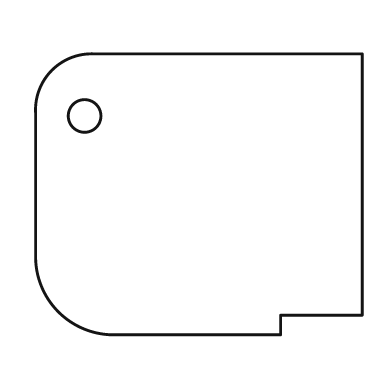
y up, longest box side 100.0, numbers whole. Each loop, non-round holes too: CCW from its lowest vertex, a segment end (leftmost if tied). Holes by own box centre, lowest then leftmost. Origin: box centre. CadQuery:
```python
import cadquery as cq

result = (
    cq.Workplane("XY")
    .moveTo(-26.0, -43.0)
    .lineTo(25.0, -43.0)
    .lineTo(25.0, -37.0)
    .lineTo(50.0, -37.0)
    .lineTo(50.0, 43.0)
    .lineTo(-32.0, 43.0)
    .threePointArc((-45.0, 38.0), (-50.0, 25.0))
    .lineTo(-50.0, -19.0)
    .threePointArc((-43.0, -36.0), (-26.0, -43.0))
    .close()
    .moveTo(-35.0, 24.0)
    .circle(5.0)
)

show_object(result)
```